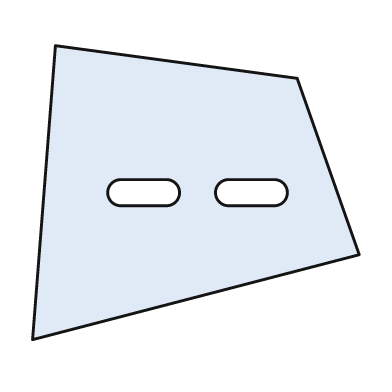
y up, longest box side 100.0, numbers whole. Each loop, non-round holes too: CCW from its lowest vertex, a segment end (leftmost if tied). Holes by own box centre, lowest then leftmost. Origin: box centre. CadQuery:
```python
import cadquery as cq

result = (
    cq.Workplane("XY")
    .moveTo(-50.0, -45.0)
    .lineTo(50.0, -19.0)
    .lineTo(31.0, 35.0)
    .lineTo(-43.0, 45.0)
    .close()
    .moveTo(-23.0, -4.0)
    .lineTo(-9.0, -4.0)
    .threePointArc((-5.0, 0.0), (-9.0, 4.0))
    .lineTo(-23.0, 4.0)
    .threePointArc((-27.0, 0.0), (-23.0, -4.0))
    .close()
    .moveTo(10.0, -4.0)
    .lineTo(24.0, -4.0)
    .threePointArc((28.0, 0.0), (24.0, 4.0))
    .lineTo(10.0, 4.0)
    .threePointArc((6.0, 0.0), (10.0, -4.0))
    .close()
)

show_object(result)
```